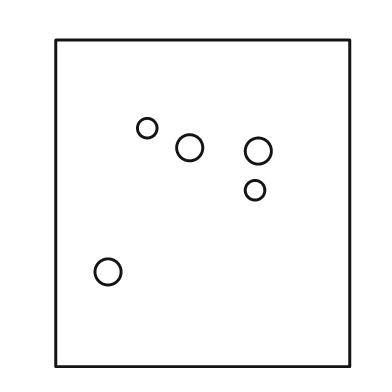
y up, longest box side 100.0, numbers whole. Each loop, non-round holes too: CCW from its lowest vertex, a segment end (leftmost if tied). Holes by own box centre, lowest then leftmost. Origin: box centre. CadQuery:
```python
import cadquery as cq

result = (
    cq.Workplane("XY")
    .moveTo(-45.0, -50.0)
    .lineTo(45.0, -50.0)
    .lineTo(45.0, 50.0)
    .lineTo(-45.0, 50.0)
    .close()
    .moveTo(-29.0, -21.0)
    .circle(4.0)
    .moveTo(16.0, 4.0)
    .circle(3.0)
    .moveTo(17.0, 16.0)
    .circle(4.0)
    .moveTo(-4.0, 17.0)
    .circle(4.0)
    .moveTo(-17.0, 23.0)
    .circle(3.0)
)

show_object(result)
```